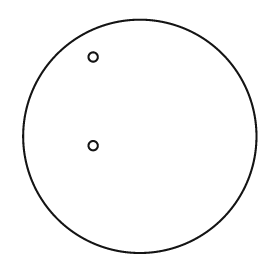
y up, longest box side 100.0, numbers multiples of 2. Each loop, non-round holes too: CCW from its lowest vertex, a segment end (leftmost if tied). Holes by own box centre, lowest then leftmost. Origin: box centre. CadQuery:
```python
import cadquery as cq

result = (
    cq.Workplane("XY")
    .moveTo(0.0, 0.0)
    .circle(50.0)
    .moveTo(-20.0, -4.0)
    .circle(2.0)
    .moveTo(-20.0, 34.0)
    .circle(2.0)
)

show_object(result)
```